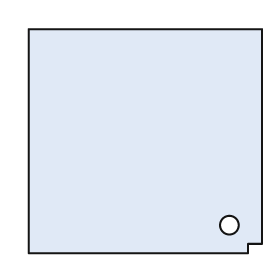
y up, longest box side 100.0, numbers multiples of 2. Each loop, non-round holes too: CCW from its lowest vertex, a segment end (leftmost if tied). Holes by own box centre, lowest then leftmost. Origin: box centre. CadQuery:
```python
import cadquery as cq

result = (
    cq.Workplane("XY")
    .moveTo(-50.0, -48.0)
    .lineTo(44.0, -48.0)
    .lineTo(44.0, -44.0)
    .lineTo(50.0, -44.0)
    .lineTo(50.0, 48.0)
    .lineTo(-50.0, 48.0)
    .close()
    .moveTo(36.0, -36.0)
    .circle(4.0)
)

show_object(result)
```